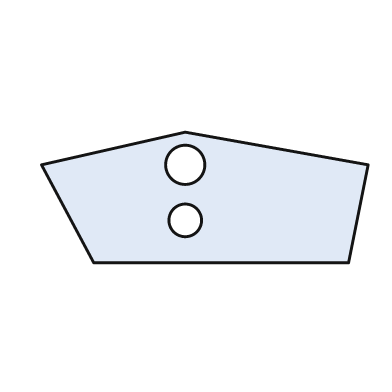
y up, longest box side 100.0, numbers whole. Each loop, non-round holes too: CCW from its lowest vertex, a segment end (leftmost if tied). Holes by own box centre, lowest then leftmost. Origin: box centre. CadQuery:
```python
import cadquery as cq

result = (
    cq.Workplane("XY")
    .moveTo(-34.0, -20.0)
    .lineTo(44.0, -20.0)
    .lineTo(50.0, 10.0)
    .lineTo(-6.0, 20.0)
    .lineTo(-50.0, 10.0)
    .close()
    .moveTo(-6.0, -7.0)
    .circle(5.0)
    .moveTo(-6.0, 10.0)
    .circle(6.0)
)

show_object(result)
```